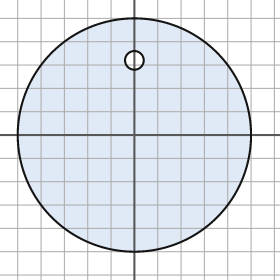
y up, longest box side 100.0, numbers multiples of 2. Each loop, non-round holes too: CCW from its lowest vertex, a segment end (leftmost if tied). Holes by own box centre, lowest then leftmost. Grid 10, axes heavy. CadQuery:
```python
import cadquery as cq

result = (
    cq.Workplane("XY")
    .moveTo(0.0, 0.0)
    .circle(50.0)
    .moveTo(0.0, 32.0)
    .circle(4.0)
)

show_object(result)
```